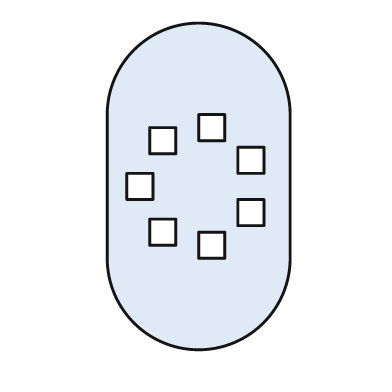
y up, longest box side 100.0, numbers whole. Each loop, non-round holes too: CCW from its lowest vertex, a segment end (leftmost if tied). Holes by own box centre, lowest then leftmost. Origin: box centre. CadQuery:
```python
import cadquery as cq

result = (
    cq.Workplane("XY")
    .moveTo(-28.0, -22.0)
    .threePointArc((0.0, -50.0), (28.0, -22.0))
    .lineTo(28.0, 22.0)
    .threePointArc((0.0, 50.0), (-28.0, 22.0))
    .close()
    .moveTo(0.0, -22.0)
    .lineTo(8.0, -22.0)
    .lineTo(8.0, -14.0)
    .lineTo(0.0, -14.0)
    .close()
    .moveTo(-15.0, -18.0)
    .lineTo(-7.0, -18.0)
    .lineTo(-7.0, -10.0)
    .lineTo(-15.0, -10.0)
    .close()
    .moveTo(12.0, -12.0)
    .lineTo(20.0, -12.0)
    .lineTo(20.0, -4.0)
    .lineTo(12.0, -4.0)
    .close()
    .moveTo(-22.0, -4.0)
    .lineTo(-14.0, -4.0)
    .lineTo(-14.0, 4.0)
    .lineTo(-22.0, 4.0)
    .close()
    .moveTo(12.0, 4.0)
    .lineTo(20.0, 4.0)
    .lineTo(20.0, 12.0)
    .lineTo(12.0, 12.0)
    .close()
    .moveTo(-15.0, 10.0)
    .lineTo(-7.0, 10.0)
    .lineTo(-7.0, 18.0)
    .lineTo(-15.0, 18.0)
    .close()
    .moveTo(0.0, 14.0)
    .lineTo(8.0, 14.0)
    .lineTo(8.0, 22.0)
    .lineTo(0.0, 22.0)
    .close()
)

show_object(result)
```